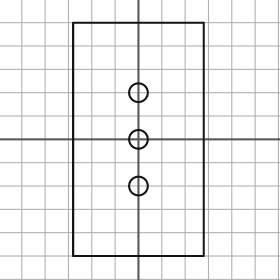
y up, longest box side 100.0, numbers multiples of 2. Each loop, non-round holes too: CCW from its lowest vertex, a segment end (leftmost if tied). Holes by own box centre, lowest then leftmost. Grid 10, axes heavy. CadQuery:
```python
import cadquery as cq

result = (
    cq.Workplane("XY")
    .moveTo(-28.0, -50.0)
    .lineTo(28.0, -50.0)
    .lineTo(28.0, 50.0)
    .lineTo(-28.0, 50.0)
    .close()
    .moveTo(0.0, -20.0)
    .circle(4.0)
    .moveTo(0.0, 0.0)
    .circle(4.0)
    .moveTo(0.0, 20.0)
    .circle(4.0)
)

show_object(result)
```